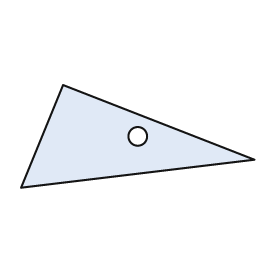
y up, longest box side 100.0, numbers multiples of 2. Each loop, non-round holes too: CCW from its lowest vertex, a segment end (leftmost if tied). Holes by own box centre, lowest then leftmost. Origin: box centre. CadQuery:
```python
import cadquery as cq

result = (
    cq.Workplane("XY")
    .moveTo(-50.0, -22.0)
    .lineTo(50.0, -10.0)
    .lineTo(-32.0, 22.0)
    .close()
    .moveTo(0.0, 0.0)
    .circle(4.0)
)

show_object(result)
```